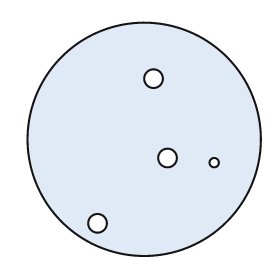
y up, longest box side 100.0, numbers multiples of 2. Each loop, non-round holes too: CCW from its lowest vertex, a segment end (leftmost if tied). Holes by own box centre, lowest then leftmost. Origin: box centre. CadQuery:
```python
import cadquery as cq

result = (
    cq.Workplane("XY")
    .moveTo(0.0, 0.0)
    .circle(50.0)
    .moveTo(-20.0, -36.0)
    .circle(4.0)
    .moveTo(30.0, -10.0)
    .circle(2.0)
    .moveTo(10.0, -8.0)
    .circle(4.0)
    .moveTo(4.0, 26.0)
    .circle(4.0)
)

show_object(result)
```